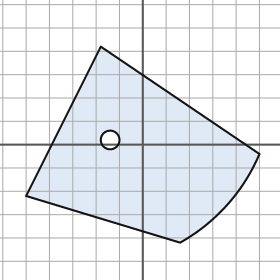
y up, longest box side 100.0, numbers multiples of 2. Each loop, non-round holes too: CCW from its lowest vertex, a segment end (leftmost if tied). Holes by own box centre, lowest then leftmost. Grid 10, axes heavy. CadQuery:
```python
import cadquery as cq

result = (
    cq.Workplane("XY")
    .moveTo(16.0, -42.0)
    .threePointArc((36.0, -26.0), (50.0, -4.0))
    .lineTo(-18.0, 42.0)
    .lineTo(-50.0, -22.0)
    .close()
    .moveTo(-14.0, 2.0)
    .circle(4.0)
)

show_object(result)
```